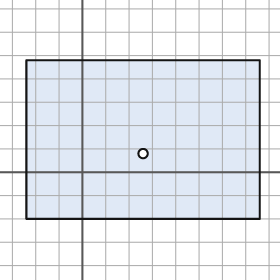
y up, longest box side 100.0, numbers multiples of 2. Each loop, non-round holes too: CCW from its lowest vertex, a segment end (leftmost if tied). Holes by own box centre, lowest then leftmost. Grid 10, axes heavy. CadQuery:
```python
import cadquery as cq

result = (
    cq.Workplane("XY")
    .moveTo(-24.0, -20.0)
    .lineTo(76.0, -20.0)
    .lineTo(76.0, 48.0)
    .lineTo(-24.0, 48.0)
    .close()
    .moveTo(26.0, 8.0)
    .circle(2.0)
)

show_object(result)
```